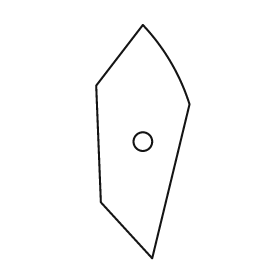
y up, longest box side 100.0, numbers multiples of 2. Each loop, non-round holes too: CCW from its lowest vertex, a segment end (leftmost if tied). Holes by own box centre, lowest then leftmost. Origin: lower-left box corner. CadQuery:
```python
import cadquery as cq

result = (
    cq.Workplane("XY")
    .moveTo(24.0, 0.0)
    .lineTo(40.0, 66.0)
    .threePointArc((32.0, 84.0), (20.0, 100.0))
    .lineTo(0.0, 74.0)
    .lineTo(2.0, 24.0)
    .close()
    .moveTo(20.0, 50.0)
    .circle(4.0)
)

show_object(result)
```